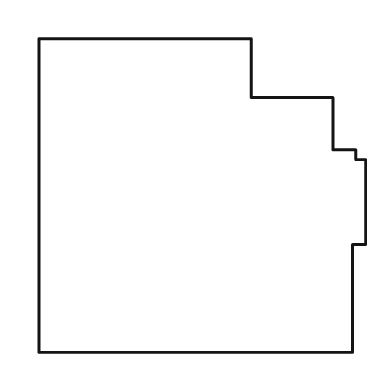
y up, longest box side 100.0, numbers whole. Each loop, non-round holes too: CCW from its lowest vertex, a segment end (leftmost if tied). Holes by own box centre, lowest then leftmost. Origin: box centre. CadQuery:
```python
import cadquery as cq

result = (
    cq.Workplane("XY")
    .moveTo(-50.0, -48.0)
    .lineTo(46.0, -48.0)
    .lineTo(46.0, -15.0)
    .lineTo(50.0, -15.0)
    .lineTo(50.0, 11.0)
    .lineTo(47.0, 11.0)
    .lineTo(47.0, 14.0)
    .lineTo(40.0, 14.0)
    .lineTo(40.0, 30.0)
    .lineTo(15.0, 30.0)
    .lineTo(15.0, 48.0)
    .lineTo(-50.0, 48.0)
    .close()
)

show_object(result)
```